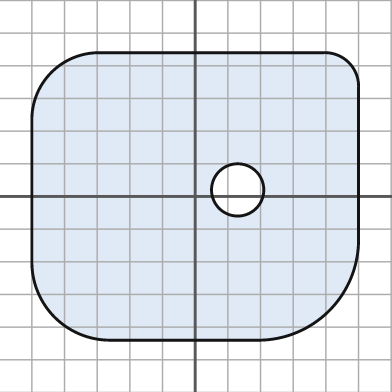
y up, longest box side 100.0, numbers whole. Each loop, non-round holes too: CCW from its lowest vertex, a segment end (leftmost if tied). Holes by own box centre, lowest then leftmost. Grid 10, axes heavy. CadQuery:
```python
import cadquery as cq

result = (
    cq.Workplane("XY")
    .moveTo(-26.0, -44.0)
    .lineTo(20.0, -44.0)
    .threePointArc((41.0, -35.0), (50.0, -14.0))
    .lineTo(50.0, 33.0)
    .threePointArc((47.0, 41.0), (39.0, 44.0))
    .lineTo(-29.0, 44.0)
    .threePointArc((-44.0, 38.0), (-50.0, 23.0))
    .lineTo(-50.0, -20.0)
    .threePointArc((-43.0, -37.0), (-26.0, -44.0))
    .close()
    .moveTo(13.0, 2.0)
    .circle(8.0)
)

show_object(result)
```